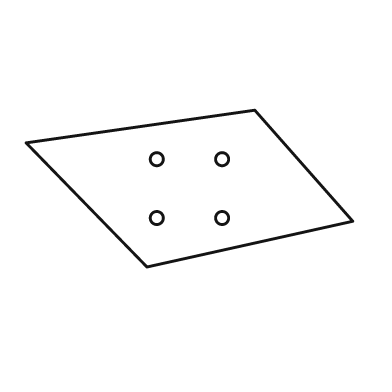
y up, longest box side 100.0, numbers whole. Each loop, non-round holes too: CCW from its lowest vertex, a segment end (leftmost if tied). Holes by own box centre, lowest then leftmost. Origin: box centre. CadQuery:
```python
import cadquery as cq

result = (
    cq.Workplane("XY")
    .moveTo(-13.0, -24.0)
    .lineTo(50.0, -10.0)
    .lineTo(20.0, 24.0)
    .lineTo(-50.0, 14.0)
    .close()
    .moveTo(-10.0, -9.0)
    .circle(2.0)
    .moveTo(10.0, -9.0)
    .circle(2.0)
    .moveTo(-10.0, 9.0)
    .circle(2.0)
    .moveTo(10.0, 9.0)
    .circle(2.0)
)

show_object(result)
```